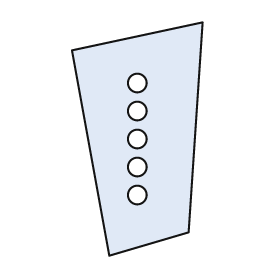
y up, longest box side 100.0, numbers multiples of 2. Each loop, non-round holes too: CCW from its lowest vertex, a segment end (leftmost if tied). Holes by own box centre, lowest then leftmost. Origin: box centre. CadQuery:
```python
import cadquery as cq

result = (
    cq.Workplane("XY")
    .moveTo(-12.0, -50.0)
    .lineTo(22.0, -40.0)
    .lineTo(28.0, 50.0)
    .lineTo(-28.0, 38.0)
    .close()
    .moveTo(0.0, -24.0)
    .circle(4.0)
    .moveTo(0.0, -12.0)
    .circle(4.0)
    .moveTo(0.0, 0.0)
    .circle(4.0)
    .moveTo(0.0, 12.0)
    .circle(4.0)
    .moveTo(0.0, 24.0)
    .circle(4.0)
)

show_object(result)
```